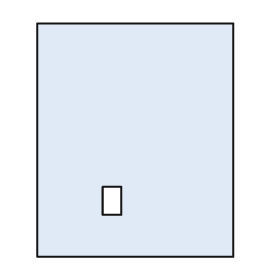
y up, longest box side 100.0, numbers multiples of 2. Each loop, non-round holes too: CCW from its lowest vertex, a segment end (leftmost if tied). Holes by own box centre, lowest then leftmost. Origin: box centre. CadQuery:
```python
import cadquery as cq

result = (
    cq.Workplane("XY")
    .moveTo(-42.0, -50.0)
    .lineTo(42.0, -50.0)
    .lineTo(42.0, 50.0)
    .lineTo(-42.0, 50.0)
    .close()
    .moveTo(-14.0, -32.0)
    .lineTo(-6.0, -32.0)
    .lineTo(-6.0, -20.0)
    .lineTo(-14.0, -20.0)
    .close()
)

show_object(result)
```